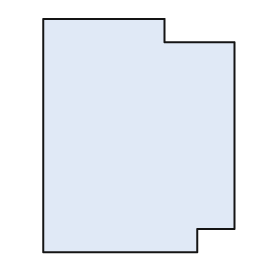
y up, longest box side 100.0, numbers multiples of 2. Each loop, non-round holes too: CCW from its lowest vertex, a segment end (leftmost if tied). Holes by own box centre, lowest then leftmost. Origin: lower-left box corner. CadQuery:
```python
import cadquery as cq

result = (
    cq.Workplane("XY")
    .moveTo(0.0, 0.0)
    .lineTo(66.0, 0.0)
    .lineTo(66.0, 10.0)
    .lineTo(82.0, 10.0)
    .lineTo(82.0, 90.0)
    .lineTo(52.0, 90.0)
    .lineTo(52.0, 100.0)
    .lineTo(0.0, 100.0)
    .close()
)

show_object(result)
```